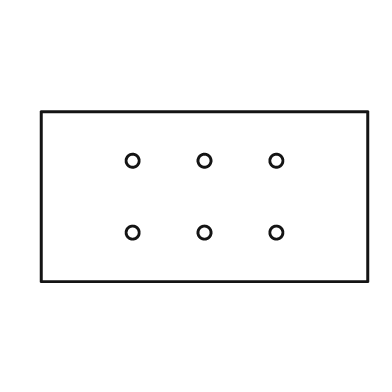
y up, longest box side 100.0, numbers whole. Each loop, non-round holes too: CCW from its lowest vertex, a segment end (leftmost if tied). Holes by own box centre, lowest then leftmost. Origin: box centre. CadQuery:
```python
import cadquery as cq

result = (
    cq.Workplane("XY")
    .moveTo(-50.0, -26.0)
    .lineTo(50.0, -26.0)
    .lineTo(50.0, 26.0)
    .lineTo(-50.0, 26.0)
    .close()
    .moveTo(-22.0, -11.0)
    .circle(2.0)
    .moveTo(0.0, -11.0)
    .circle(2.0)
    .moveTo(22.0, -11.0)
    .circle(2.0)
    .moveTo(-22.0, 11.0)
    .circle(2.0)
    .moveTo(0.0, 11.0)
    .circle(2.0)
    .moveTo(22.0, 11.0)
    .circle(2.0)
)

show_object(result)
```